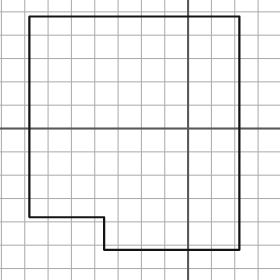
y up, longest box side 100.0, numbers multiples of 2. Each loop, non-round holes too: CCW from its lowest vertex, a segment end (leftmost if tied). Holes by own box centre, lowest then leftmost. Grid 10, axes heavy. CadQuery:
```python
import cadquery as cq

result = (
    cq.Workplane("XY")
    .moveTo(-36.0, -52.0)
    .lineTo(22.0, -52.0)
    .lineTo(22.0, 48.0)
    .lineTo(-68.0, 48.0)
    .lineTo(-68.0, -38.0)
    .lineTo(-36.0, -38.0)
    .close()
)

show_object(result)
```